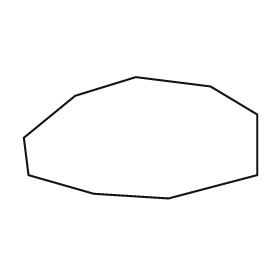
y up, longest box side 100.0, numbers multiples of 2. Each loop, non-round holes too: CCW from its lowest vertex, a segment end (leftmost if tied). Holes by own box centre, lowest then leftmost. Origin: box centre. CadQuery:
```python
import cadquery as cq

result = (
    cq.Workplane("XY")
    .moveTo(12.0, -26.0)
    .lineTo(50.0, -16.0)
    .lineTo(50.0, 10.0)
    .lineTo(30.0, 22.0)
    .lineTo(-2.0, 26.0)
    .lineTo(-28.0, 18.0)
    .lineTo(-50.0, 0.0)
    .lineTo(-48.0, -16.0)
    .lineTo(-20.0, -24.0)
    .close()
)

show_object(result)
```